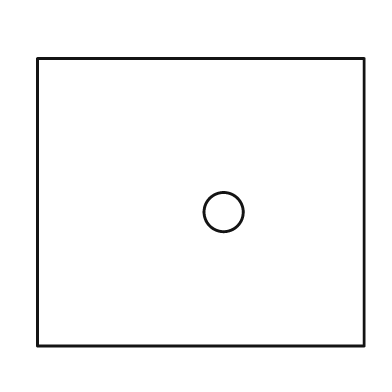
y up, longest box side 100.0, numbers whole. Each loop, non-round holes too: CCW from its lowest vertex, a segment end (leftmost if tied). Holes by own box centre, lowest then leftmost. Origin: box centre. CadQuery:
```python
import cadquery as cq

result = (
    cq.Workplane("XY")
    .moveTo(-50.0, -44.0)
    .lineTo(50.0, -44.0)
    .lineTo(50.0, 44.0)
    .lineTo(-50.0, 44.0)
    .close()
    .moveTo(7.0, -3.0)
    .circle(6.0)
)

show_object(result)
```